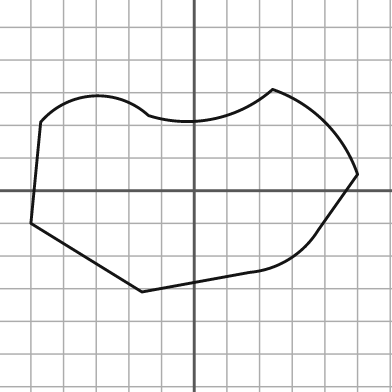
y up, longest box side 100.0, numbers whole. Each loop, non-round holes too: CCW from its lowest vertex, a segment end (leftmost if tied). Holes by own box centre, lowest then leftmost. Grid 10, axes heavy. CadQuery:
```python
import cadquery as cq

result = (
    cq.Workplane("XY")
    .moveTo(-16.0, -31.0)
    .lineTo(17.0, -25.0)
    .threePointArc((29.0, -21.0), (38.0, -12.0))
    .lineTo(50.0, 5.0)
    .threePointArc((40.0, 21.0), (24.0, 31.0))
    .threePointArc((6.0, 22.0), (-14.0, 23.0))
    .threePointArc((-31.0, 29.0), (-47.0, 21.0))
    .lineTo(-50.0, -10.0)
    .close()
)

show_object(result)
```